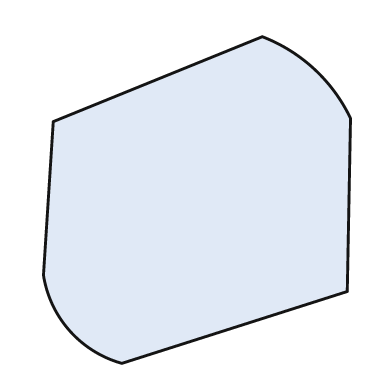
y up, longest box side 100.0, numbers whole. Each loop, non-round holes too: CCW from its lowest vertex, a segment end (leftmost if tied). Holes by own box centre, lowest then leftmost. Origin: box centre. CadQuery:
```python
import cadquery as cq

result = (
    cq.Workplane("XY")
    .moveTo(-23.0, -50.0)
    .lineTo(46.0, -28.0)
    .lineTo(47.0, 25.0)
    .threePointArc((36.0, 40.0), (20.0, 50.0))
    .lineTo(-44.0, 24.0)
    .lineTo(-47.0, -23.0)
    .threePointArc((-39.0, -40.0), (-23.0, -50.0))
    .close()
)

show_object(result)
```